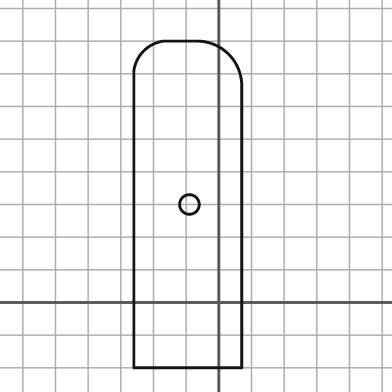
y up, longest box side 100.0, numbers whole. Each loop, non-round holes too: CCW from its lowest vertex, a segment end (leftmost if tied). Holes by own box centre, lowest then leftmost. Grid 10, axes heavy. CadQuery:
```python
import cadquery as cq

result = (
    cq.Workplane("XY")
    .moveTo(-26.0, -20.0)
    .lineTo(7.0, -20.0)
    .lineTo(7.0, 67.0)
    .threePointArc((3.0, 76.0), (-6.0, 80.0))
    .lineTo(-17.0, 80.0)
    .threePointArc((-23.0, 77.0), (-26.0, 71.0))
    .close()
    .moveTo(-9.0, 30.0)
    .circle(3.0)
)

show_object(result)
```